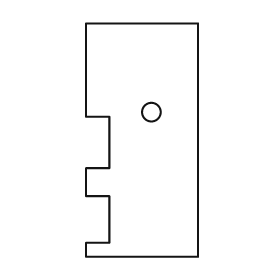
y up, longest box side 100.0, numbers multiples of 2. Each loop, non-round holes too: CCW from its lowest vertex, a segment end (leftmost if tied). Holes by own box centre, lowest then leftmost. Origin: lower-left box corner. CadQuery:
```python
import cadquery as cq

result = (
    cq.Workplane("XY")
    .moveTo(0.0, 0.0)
    .lineTo(48.0, 0.0)
    .lineTo(48.0, 100.0)
    .lineTo(0.0, 100.0)
    .lineTo(0.0, 60.0)
    .lineTo(10.0, 60.0)
    .lineTo(10.0, 38.0)
    .lineTo(0.0, 38.0)
    .lineTo(0.0, 26.0)
    .lineTo(10.0, 26.0)
    .lineTo(10.0, 6.0)
    .lineTo(0.0, 6.0)
    .close()
    .moveTo(28.0, 62.0)
    .circle(4.0)
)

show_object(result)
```